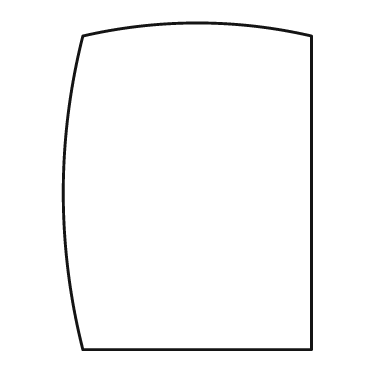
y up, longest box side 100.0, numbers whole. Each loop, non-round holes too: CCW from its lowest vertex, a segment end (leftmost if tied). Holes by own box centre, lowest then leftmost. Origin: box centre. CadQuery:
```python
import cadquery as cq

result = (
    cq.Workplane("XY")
    .moveTo(-32.0, -50.0)
    .lineTo(38.0, -50.0)
    .lineTo(38.0, 46.0)
    .threePointArc((3.0, 50.0), (-32.0, 46.0))
    .threePointArc((-38.0, -2.0), (-32.0, -50.0))
    .close()
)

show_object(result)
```